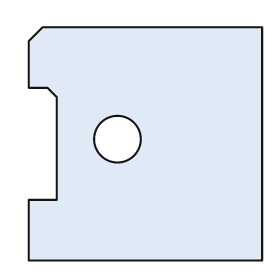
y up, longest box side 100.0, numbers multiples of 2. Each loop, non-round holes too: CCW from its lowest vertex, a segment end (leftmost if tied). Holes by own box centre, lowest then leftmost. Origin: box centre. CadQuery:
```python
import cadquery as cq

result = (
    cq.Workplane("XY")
    .moveTo(-50.0, -50.0)
    .lineTo(50.0, -50.0)
    .lineTo(50.0, 50.0)
    .lineTo(-44.0, 50.0)
    .lineTo(-50.0, 44.0)
    .lineTo(-50.0, 24.0)
    .lineTo(-42.0, 24.0)
    .lineTo(-38.0, 20.0)
    .lineTo(-38.0, -24.0)
    .lineTo(-50.0, -24.0)
    .close()
    .moveTo(-12.0, 2.0)
    .circle(10.0)
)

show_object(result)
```